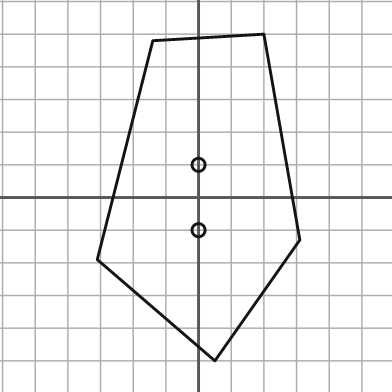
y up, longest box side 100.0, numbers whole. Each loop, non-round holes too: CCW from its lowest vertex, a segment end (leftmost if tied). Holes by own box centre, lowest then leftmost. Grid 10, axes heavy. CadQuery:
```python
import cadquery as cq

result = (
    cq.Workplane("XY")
    .moveTo(5.0, -50.0)
    .lineTo(31.0, -13.0)
    .lineTo(20.0, 50.0)
    .lineTo(-14.0, 48.0)
    .lineTo(-31.0, -19.0)
    .close()
    .moveTo(0.0, -10.0)
    .circle(2.0)
    .moveTo(0.0, 10.0)
    .circle(2.0)
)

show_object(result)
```